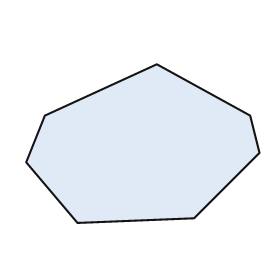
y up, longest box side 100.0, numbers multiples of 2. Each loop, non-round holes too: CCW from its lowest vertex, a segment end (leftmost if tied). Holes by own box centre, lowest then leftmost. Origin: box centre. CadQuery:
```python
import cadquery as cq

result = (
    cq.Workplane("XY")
    .moveTo(-28.0, -34.0)
    .lineTo(22.0, -32.0)
    .lineTo(50.0, -4.0)
    .lineTo(46.0, 12.0)
    .lineTo(6.0, 34.0)
    .lineTo(-42.0, 12.0)
    .lineTo(-50.0, -8.0)
    .close()
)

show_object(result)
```